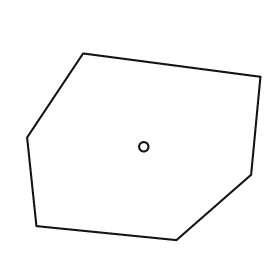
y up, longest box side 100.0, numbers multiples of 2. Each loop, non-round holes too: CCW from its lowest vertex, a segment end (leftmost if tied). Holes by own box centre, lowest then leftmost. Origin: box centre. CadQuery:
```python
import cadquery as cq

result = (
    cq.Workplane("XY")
    .moveTo(14.0, -40.0)
    .lineTo(46.0, -12.0)
    .lineTo(50.0, 30.0)
    .lineTo(-26.0, 40.0)
    .lineTo(-50.0, 4.0)
    .lineTo(-46.0, -34.0)
    .close()
    .moveTo(0.0, 0.0)
    .circle(2.0)
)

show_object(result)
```